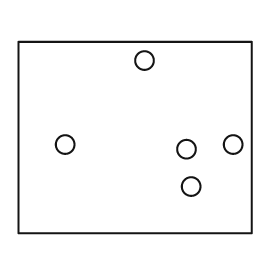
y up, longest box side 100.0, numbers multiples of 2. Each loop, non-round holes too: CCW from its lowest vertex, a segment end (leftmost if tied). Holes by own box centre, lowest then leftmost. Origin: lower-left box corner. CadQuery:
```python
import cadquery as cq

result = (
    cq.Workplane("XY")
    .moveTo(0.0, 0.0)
    .lineTo(100.0, 0.0)
    .lineTo(100.0, 82.0)
    .lineTo(0.0, 82.0)
    .close()
    .moveTo(74.0, 20.0)
    .circle(4.0)
    .moveTo(72.0, 36.0)
    .circle(4.0)
    .moveTo(20.0, 38.0)
    .circle(4.0)
    .moveTo(92.0, 38.0)
    .circle(4.0)
    .moveTo(54.0, 74.0)
    .circle(4.0)
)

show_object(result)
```